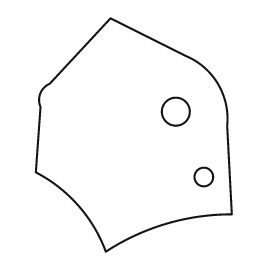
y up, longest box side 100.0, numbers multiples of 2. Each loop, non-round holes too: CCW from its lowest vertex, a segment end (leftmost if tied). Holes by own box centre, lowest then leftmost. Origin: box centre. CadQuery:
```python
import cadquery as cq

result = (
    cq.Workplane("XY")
    .moveTo(-12.0, -50.0)
    .threePointArc((14.0, -38.0), (42.0, -34.0))
    .lineTo(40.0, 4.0)
    .threePointArc((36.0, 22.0), (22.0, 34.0))
    .lineTo(-10.0, 50.0)
    .lineTo(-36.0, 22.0)
    .threePointArc((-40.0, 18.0), (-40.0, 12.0))
    .lineTo(-42.0, -16.0)
    .threePointArc((-24.0, -30.0), (-12.0, -50.0))
    .close()
    .moveTo(30.0, -18.0)
    .circle(4.0)
    .moveTo(18.0, 10.0)
    .circle(6.0)
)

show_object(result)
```